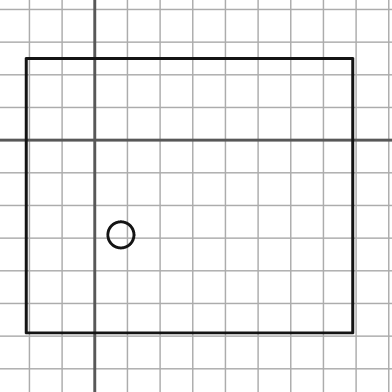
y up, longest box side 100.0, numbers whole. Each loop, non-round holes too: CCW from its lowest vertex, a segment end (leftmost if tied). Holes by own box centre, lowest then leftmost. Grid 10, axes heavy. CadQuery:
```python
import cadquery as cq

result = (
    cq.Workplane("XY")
    .moveTo(-21.0, -59.0)
    .lineTo(79.0, -59.0)
    .lineTo(79.0, 25.0)
    .lineTo(-21.0, 25.0)
    .close()
    .moveTo(8.0, -29.0)
    .circle(4.0)
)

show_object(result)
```